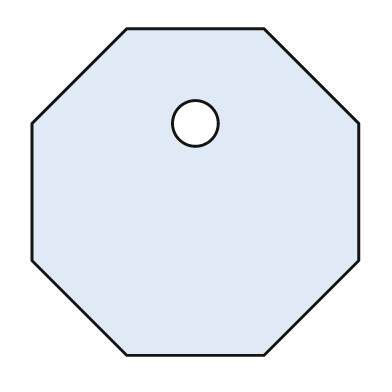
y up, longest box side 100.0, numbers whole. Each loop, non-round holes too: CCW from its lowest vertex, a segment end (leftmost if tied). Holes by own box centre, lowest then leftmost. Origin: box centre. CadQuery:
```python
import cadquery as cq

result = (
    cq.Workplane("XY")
    .moveTo(-21.0, -50.0)
    .lineTo(21.0, -50.0)
    .lineTo(50.0, -21.0)
    .lineTo(50.0, 21.0)
    .lineTo(21.0, 50.0)
    .lineTo(-21.0, 50.0)
    .lineTo(-50.0, 21.0)
    .lineTo(-50.0, -21.0)
    .close()
    .moveTo(0.0, 21.0)
    .circle(7.0)
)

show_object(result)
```